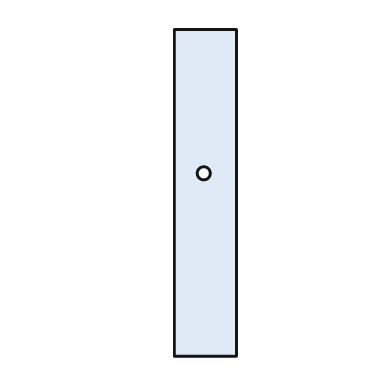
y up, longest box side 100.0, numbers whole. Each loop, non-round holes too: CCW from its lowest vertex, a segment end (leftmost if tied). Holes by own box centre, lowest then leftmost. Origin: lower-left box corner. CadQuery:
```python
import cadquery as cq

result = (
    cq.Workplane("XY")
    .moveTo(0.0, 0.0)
    .lineTo(19.0, 0.0)
    .lineTo(19.0, 100.0)
    .lineTo(0.0, 100.0)
    .close()
    .moveTo(9.0, 56.0)
    .circle(2.0)
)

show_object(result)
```